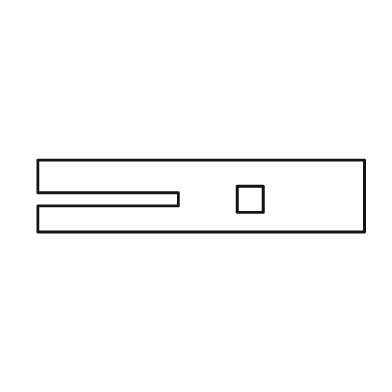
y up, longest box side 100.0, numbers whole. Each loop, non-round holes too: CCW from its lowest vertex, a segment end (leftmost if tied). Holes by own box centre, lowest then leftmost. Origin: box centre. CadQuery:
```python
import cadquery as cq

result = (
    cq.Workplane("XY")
    .moveTo(-50.0, -11.0)
    .lineTo(50.0, -11.0)
    .lineTo(50.0, 11.0)
    .lineTo(-50.0, 11.0)
    .lineTo(-50.0, 1.0)
    .lineTo(-7.0, 1.0)
    .lineTo(-7.0, -3.0)
    .lineTo(-50.0, -3.0)
    .close()
    .moveTo(11.0, -5.0)
    .lineTo(19.0, -5.0)
    .lineTo(19.0, 3.0)
    .lineTo(11.0, 3.0)
    .close()
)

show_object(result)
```